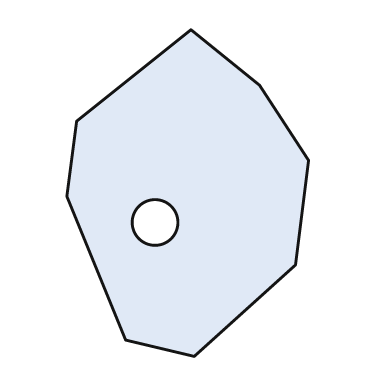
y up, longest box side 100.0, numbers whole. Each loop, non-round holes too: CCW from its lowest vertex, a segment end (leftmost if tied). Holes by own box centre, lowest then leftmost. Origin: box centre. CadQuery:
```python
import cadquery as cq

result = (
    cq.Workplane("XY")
    .moveTo(2.0, -50.0)
    .lineTo(33.0, -22.0)
    .lineTo(37.0, 10.0)
    .lineTo(22.0, 33.0)
    .lineTo(1.0, 50.0)
    .lineTo(-34.0, 22.0)
    .lineTo(-37.0, -1.0)
    .lineTo(-19.0, -45.0)
    .close()
    .moveTo(-10.0, -9.0)
    .circle(7.0)
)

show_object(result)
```